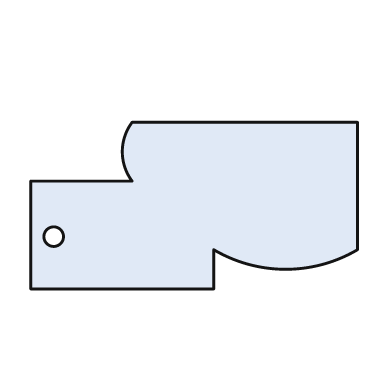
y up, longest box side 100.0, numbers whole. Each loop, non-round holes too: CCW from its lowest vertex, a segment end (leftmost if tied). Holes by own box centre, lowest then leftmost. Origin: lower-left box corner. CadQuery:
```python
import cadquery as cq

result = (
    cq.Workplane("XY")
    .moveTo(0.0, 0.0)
    .lineTo(56.0, 0.0)
    .lineTo(56.0, 12.0)
    .threePointArc((78.0, 6.0), (100.0, 12.0))
    .lineTo(100.0, 51.0)
    .lineTo(31.0, 51.0)
    .threePointArc((28.0, 42.0), (31.0, 33.0))
    .lineTo(0.0, 33.0)
    .close()
    .moveTo(7.0, 16.0)
    .circle(3.0)
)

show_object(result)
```